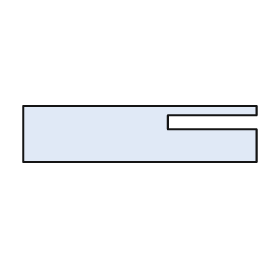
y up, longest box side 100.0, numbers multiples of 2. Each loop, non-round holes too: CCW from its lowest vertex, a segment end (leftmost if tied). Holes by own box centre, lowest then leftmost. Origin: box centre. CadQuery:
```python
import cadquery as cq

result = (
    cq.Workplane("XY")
    .moveTo(-50.0, -12.0)
    .lineTo(50.0, -12.0)
    .lineTo(50.0, 2.0)
    .lineTo(12.0, 2.0)
    .lineTo(12.0, 8.0)
    .lineTo(50.0, 8.0)
    .lineTo(50.0, 12.0)
    .lineTo(-50.0, 12.0)
    .close()
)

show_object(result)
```